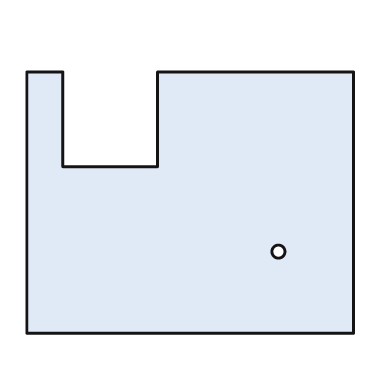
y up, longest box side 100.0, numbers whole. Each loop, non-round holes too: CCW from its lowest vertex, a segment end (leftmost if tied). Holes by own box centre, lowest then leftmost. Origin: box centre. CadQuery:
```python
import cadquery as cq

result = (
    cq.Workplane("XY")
    .moveTo(-50.0, -40.0)
    .lineTo(50.0, -40.0)
    .lineTo(50.0, 40.0)
    .lineTo(-10.0, 40.0)
    .lineTo(-10.0, 11.0)
    .lineTo(-39.0, 11.0)
    .lineTo(-39.0, 40.0)
    .lineTo(-50.0, 40.0)
    .close()
    .moveTo(27.0, -15.0)
    .circle(2.0)
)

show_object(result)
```